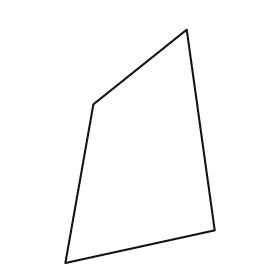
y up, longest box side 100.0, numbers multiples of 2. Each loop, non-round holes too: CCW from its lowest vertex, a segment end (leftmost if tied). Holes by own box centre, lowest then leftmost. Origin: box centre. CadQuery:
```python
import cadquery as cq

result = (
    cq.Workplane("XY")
    .moveTo(-32.0, -50.0)
    .lineTo(32.0, -36.0)
    .lineTo(20.0, 50.0)
    .lineTo(-20.0, 18.0)
    .close()
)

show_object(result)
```